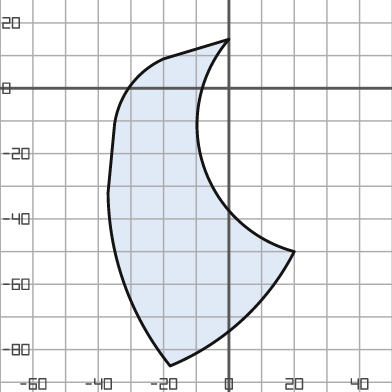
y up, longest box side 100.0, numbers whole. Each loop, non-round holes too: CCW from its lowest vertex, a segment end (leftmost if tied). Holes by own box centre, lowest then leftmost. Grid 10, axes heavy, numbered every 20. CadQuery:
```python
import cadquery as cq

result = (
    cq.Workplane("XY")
    .moveTo(-18.0, -85.0)
    .threePointArc((4.0, -71.0), (20.0, -50.0))
    .threePointArc((-8.0, -23.0), (0.0, 15.0))
    .lineTo(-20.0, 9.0)
    .threePointArc((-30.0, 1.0), (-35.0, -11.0))
    .lineTo(-37.0, -32.0)
    .threePointArc((-32.0, -60.0), (-18.0, -85.0))
    .close()
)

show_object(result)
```